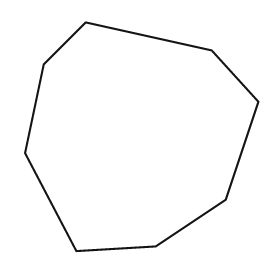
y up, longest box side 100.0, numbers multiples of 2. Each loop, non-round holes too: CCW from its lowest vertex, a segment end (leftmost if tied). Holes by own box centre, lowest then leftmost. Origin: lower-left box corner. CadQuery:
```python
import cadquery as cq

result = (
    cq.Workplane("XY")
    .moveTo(22.0, 0.0)
    .lineTo(56.0, 2.0)
    .lineTo(86.0, 22.0)
    .lineTo(100.0, 64.0)
    .lineTo(80.0, 86.0)
    .lineTo(26.0, 98.0)
    .lineTo(8.0, 80.0)
    .lineTo(0.0, 42.0)
    .close()
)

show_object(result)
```